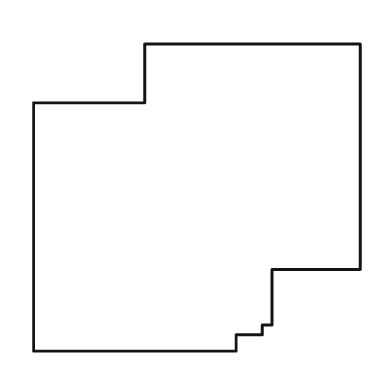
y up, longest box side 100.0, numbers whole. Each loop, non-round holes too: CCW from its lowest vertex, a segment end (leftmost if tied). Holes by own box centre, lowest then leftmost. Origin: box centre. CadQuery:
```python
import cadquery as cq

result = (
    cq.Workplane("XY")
    .moveTo(-50.0, -47.0)
    .lineTo(12.0, -47.0)
    .lineTo(12.0, -42.0)
    .lineTo(20.0, -42.0)
    .lineTo(20.0, -39.0)
    .lineTo(23.0, -39.0)
    .lineTo(23.0, -22.0)
    .lineTo(50.0, -22.0)
    .lineTo(50.0, 47.0)
    .lineTo(-16.0, 47.0)
    .lineTo(-16.0, 29.0)
    .lineTo(-50.0, 29.0)
    .close()
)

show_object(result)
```